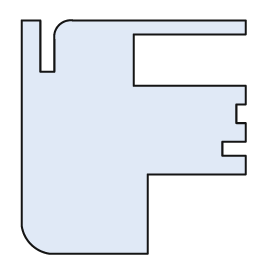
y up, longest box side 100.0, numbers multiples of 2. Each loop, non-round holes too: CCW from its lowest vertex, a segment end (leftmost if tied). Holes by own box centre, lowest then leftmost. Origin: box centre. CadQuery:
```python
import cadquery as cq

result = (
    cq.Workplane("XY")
    .moveTo(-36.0, -50.0)
    .lineTo(6.0, -50.0)
    .lineTo(6.0, -16.0)
    .lineTo(48.0, -16.0)
    .lineTo(48.0, -8.0)
    .lineTo(38.0, -8.0)
    .lineTo(38.0, -2.0)
    .lineTo(48.0, -2.0)
    .lineTo(48.0, 6.0)
    .lineTo(44.0, 6.0)
    .lineTo(44.0, 14.0)
    .lineTo(48.0, 14.0)
    .lineTo(48.0, 22.0)
    .lineTo(0.0, 22.0)
    .lineTo(0.0, 44.0)
    .lineTo(48.0, 44.0)
    .lineTo(48.0, 50.0)
    .lineTo(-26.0, 50.0)
    .threePointArc((-32.0, 48.0), (-34.0, 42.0))
    .lineTo(-34.0, 28.0)
    .lineTo(-40.0, 28.0)
    .lineTo(-40.0, 50.0)
    .lineTo(-48.0, 50.0)
    .lineTo(-48.0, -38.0)
    .threePointArc((-44.0, -46.0), (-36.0, -50.0))
    .close()
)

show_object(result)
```